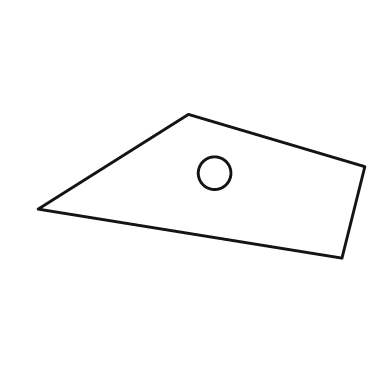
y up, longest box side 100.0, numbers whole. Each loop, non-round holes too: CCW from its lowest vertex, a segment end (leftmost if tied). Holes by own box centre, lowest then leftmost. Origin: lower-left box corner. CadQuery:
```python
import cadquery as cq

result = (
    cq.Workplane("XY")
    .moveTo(93.0, 0.0)
    .lineTo(100.0, 28.0)
    .lineTo(46.0, 44.0)
    .lineTo(0.0, 15.0)
    .close()
    .moveTo(54.0, 26.0)
    .circle(5.0)
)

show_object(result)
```